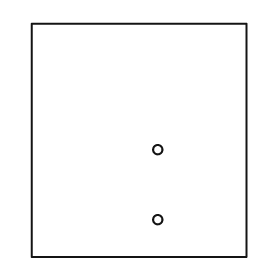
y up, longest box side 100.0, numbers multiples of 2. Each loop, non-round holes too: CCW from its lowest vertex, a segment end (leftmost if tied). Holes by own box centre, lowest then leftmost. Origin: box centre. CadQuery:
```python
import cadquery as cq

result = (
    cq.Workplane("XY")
    .moveTo(-46.0, -50.0)
    .lineTo(46.0, -50.0)
    .lineTo(46.0, 50.0)
    .lineTo(-46.0, 50.0)
    .close()
    .moveTo(8.0, -34.0)
    .circle(2.0)
    .moveTo(8.0, -4.0)
    .circle(2.0)
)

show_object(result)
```